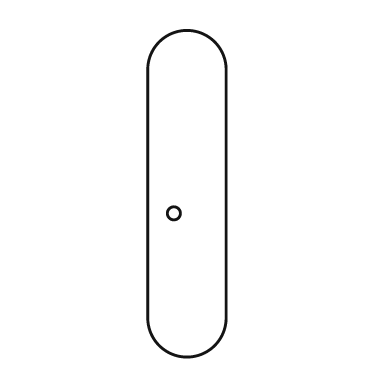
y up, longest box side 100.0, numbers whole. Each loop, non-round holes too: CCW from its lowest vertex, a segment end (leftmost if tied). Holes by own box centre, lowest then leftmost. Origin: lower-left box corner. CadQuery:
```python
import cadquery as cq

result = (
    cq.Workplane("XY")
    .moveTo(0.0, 12.0)
    .threePointArc((12.0, 0.0), (24.0, 12.0))
    .lineTo(24.0, 88.0)
    .threePointArc((12.0, 100.0), (0.0, 88.0))
    .close()
    .moveTo(8.0, 44.0)
    .circle(2.0)
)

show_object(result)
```